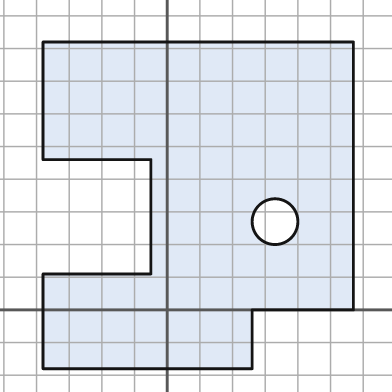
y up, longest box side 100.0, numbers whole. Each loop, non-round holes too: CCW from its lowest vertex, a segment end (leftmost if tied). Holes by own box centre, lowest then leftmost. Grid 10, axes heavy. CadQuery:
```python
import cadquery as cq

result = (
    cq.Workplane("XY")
    .moveTo(-38.0, -18.0)
    .lineTo(26.0, -18.0)
    .lineTo(26.0, 0.0)
    .lineTo(57.0, 0.0)
    .lineTo(57.0, 82.0)
    .lineTo(-38.0, 82.0)
    .lineTo(-38.0, 46.0)
    .lineTo(-5.0, 46.0)
    .lineTo(-5.0, 11.0)
    .lineTo(-38.0, 11.0)
    .close()
    .moveTo(33.0, 27.0)
    .circle(7.0)
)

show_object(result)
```